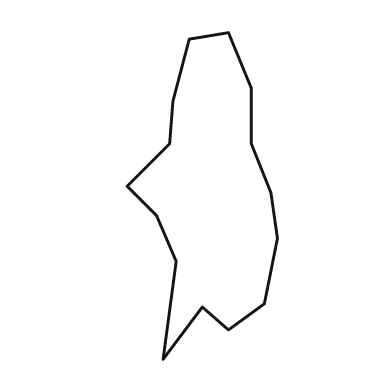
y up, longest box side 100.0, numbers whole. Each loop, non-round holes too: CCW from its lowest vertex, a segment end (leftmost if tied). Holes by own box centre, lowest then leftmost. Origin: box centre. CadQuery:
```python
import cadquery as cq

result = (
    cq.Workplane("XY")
    .moveTo(-12.0, -50.0)
    .lineTo(0.0, -34.0)
    .lineTo(8.0, -41.0)
    .lineTo(19.0, -33.0)
    .lineTo(23.0, -13.0)
    .lineTo(21.0, 1.0)
    .lineTo(15.0, 16.0)
    .lineTo(15.0, 33.0)
    .lineTo(8.0, 50.0)
    .lineTo(-4.0, 48.0)
    .lineTo(-9.0, 29.0)
    .lineTo(-10.0, 16.0)
    .lineTo(-23.0, 3.0)
    .lineTo(-14.0, -6.0)
    .lineTo(-8.0, -20.0)
    .close()
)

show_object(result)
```